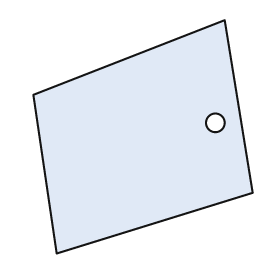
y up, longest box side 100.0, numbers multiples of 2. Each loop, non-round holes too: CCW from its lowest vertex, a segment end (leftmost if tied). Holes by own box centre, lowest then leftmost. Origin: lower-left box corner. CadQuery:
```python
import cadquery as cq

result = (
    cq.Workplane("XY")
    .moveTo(10.0, 0.0)
    .lineTo(94.0, 26.0)
    .lineTo(82.0, 100.0)
    .lineTo(0.0, 68.0)
    .close()
    .moveTo(78.0, 56.0)
    .circle(4.0)
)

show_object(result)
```